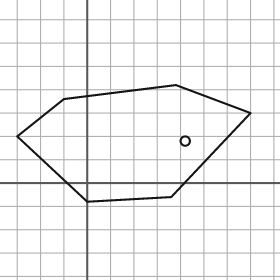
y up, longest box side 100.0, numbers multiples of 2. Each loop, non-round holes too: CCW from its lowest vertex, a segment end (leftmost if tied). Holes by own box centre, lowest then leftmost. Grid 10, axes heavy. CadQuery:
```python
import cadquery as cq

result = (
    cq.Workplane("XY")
    .moveTo(0.0, -8.0)
    .lineTo(36.0, -6.0)
    .lineTo(70.0, 30.0)
    .lineTo(38.0, 42.0)
    .lineTo(-10.0, 36.0)
    .lineTo(-30.0, 20.0)
    .close()
    .moveTo(42.0, 18.0)
    .circle(2.0)
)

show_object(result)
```